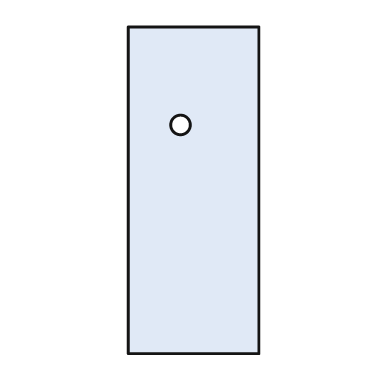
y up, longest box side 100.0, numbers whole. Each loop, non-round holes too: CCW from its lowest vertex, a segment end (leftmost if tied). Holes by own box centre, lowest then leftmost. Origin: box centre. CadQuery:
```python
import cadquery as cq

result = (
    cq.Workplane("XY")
    .moveTo(-20.0, -50.0)
    .lineTo(20.0, -50.0)
    .lineTo(20.0, 50.0)
    .lineTo(-20.0, 50.0)
    .close()
    .moveTo(-4.0, 20.0)
    .circle(3.0)
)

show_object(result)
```